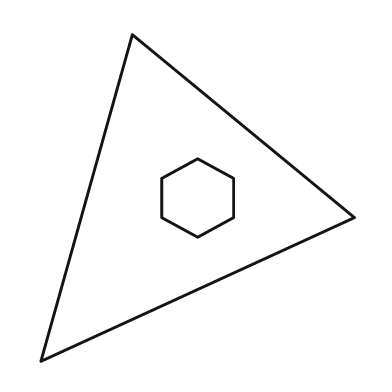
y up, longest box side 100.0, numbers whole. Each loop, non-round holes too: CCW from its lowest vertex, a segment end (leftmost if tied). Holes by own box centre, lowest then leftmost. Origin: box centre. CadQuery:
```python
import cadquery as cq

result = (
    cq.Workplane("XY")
    .moveTo(-48.0, -50.0)
    .lineTo(48.0, -6.0)
    .lineTo(-20.0, 50.0)
    .close()
    .moveTo(0.0, -12.0)
    .lineTo(11.0, -6.0)
    .lineTo(11.0, 6.0)
    .lineTo(0.0, 12.0)
    .lineTo(-11.0, 6.0)
    .lineTo(-11.0, -6.0)
    .close()
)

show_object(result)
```